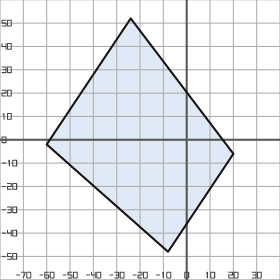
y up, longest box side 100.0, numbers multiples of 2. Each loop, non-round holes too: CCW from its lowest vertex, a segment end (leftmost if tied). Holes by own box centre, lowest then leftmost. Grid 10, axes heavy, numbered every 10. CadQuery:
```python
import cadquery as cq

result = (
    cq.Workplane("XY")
    .moveTo(-8.0, -48.0)
    .lineTo(20.0, -6.0)
    .lineTo(-24.0, 52.0)
    .lineTo(-60.0, -2.0)
    .close()
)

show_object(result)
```